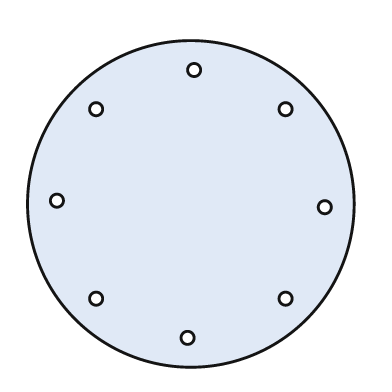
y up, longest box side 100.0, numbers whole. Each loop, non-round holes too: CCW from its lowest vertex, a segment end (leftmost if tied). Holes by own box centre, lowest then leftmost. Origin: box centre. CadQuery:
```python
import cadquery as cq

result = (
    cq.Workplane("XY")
    .moveTo(0.0, 0.0)
    .circle(50.0)
    .moveTo(-1.0, -41.0)
    .circle(2.0)
    .moveTo(-29.0, -29.0)
    .circle(2.0)
    .moveTo(29.0, -29.0)
    .circle(2.0)
    .moveTo(41.0, -1.0)
    .circle(2.0)
    .moveTo(-41.0, 1.0)
    .circle(2.0)
    .moveTo(-29.0, 29.0)
    .circle(2.0)
    .moveTo(29.0, 29.0)
    .circle(2.0)
    .moveTo(1.0, 41.0)
    .circle(2.0)
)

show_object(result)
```